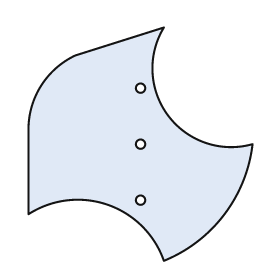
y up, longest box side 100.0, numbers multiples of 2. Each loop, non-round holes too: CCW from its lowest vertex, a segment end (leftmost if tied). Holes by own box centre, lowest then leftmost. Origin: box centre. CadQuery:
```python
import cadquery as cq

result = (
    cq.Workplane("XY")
    .moveTo(10.0, -50.0)
    .threePointArc((36.0, -30.0), (48.0, 0.0))
    .threePointArc((12.0, 12.0), (10.0, 50.0))
    .lineTo(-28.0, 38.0)
    .threePointArc((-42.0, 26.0), (-48.0, 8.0))
    .lineTo(-48.0, -30.0)
    .threePointArc((-14.0, -26.0), (10.0, -50.0))
    .close()
    .moveTo(0.0, -24.0)
    .circle(2.0)
    .moveTo(0.0, 0.0)
    .circle(2.0)
    .moveTo(0.0, 24.0)
    .circle(2.0)
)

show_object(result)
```